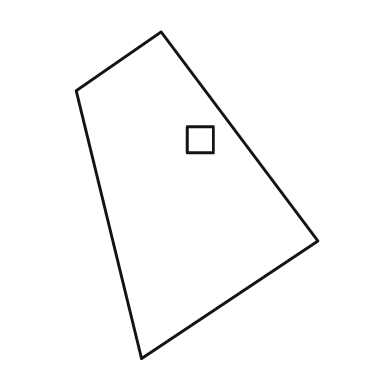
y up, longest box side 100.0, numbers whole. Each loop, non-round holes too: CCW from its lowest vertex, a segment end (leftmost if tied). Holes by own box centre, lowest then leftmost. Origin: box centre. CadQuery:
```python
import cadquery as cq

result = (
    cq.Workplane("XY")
    .moveTo(-17.0, -50.0)
    .lineTo(37.0, -14.0)
    .lineTo(-11.0, 50.0)
    .lineTo(-37.0, 32.0)
    .close()
    .moveTo(-3.0, 13.0)
    .lineTo(5.0, 13.0)
    .lineTo(5.0, 21.0)
    .lineTo(-3.0, 21.0)
    .close()
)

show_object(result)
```